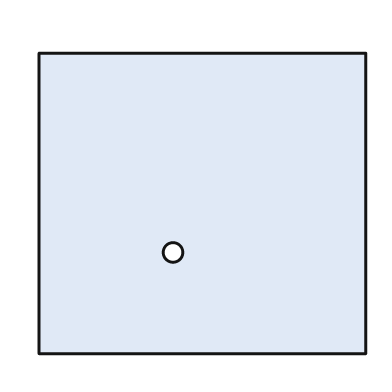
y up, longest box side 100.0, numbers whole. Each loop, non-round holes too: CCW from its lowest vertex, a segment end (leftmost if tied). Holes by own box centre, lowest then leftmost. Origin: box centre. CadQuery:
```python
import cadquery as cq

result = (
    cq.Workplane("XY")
    .moveTo(-50.0, -46.0)
    .lineTo(50.0, -46.0)
    .lineTo(50.0, 46.0)
    .lineTo(-50.0, 46.0)
    .close()
    .moveTo(-9.0, -15.0)
    .circle(3.0)
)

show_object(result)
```